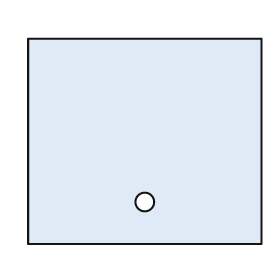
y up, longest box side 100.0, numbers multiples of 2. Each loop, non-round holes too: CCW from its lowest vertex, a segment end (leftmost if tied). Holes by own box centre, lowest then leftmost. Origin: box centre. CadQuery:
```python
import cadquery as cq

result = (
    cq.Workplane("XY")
    .moveTo(-50.0, -44.0)
    .lineTo(50.0, -44.0)
    .lineTo(50.0, 44.0)
    .lineTo(-50.0, 44.0)
    .close()
    .moveTo(0.0, -26.0)
    .circle(4.0)
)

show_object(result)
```